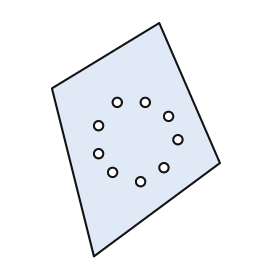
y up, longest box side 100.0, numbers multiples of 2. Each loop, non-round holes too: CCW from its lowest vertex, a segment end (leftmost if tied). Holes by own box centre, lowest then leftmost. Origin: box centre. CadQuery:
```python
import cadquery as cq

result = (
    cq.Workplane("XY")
    .moveTo(-18.0, -50.0)
    .lineTo(36.0, -10.0)
    .lineTo(10.0, 50.0)
    .lineTo(-36.0, 22.0)
    .close()
    .moveTo(2.0, -18.0)
    .circle(2.0)
    .moveTo(-10.0, -14.0)
    .circle(2.0)
    .moveTo(12.0, -12.0)
    .circle(2.0)
    .moveTo(-16.0, -6.0)
    .circle(2.0)
    .moveTo(18.0, 0.0)
    .circle(2.0)
    .moveTo(-16.0, 6.0)
    .circle(2.0)
    .moveTo(14.0, 10.0)
    .circle(2.0)
    .moveTo(-8.0, 16.0)
    .circle(2.0)
    .moveTo(4.0, 16.0)
    .circle(2.0)
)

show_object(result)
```